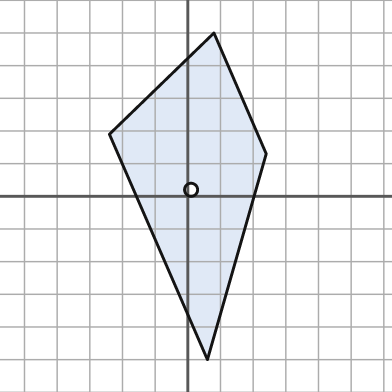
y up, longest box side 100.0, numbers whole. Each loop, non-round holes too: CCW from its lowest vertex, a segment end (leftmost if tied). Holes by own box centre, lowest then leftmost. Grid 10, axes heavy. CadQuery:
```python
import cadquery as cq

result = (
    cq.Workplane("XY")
    .moveTo(6.0, -50.0)
    .lineTo(24.0, 13.0)
    .lineTo(8.0, 50.0)
    .lineTo(-24.0, 19.0)
    .close()
    .moveTo(1.0, 2.0)
    .circle(2.0)
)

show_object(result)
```